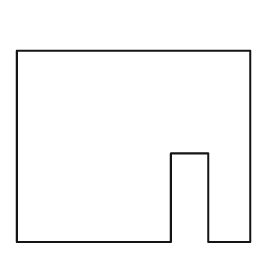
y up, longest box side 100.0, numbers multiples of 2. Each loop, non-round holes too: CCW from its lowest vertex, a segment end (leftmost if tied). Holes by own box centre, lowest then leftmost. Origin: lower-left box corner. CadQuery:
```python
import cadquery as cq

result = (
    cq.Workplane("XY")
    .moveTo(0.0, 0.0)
    .lineTo(66.0, 0.0)
    .lineTo(66.0, 38.0)
    .lineTo(82.0, 38.0)
    .lineTo(82.0, 0.0)
    .lineTo(100.0, 0.0)
    .lineTo(100.0, 82.0)
    .lineTo(0.0, 82.0)
    .close()
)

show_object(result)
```